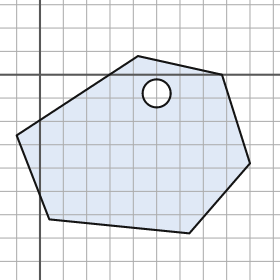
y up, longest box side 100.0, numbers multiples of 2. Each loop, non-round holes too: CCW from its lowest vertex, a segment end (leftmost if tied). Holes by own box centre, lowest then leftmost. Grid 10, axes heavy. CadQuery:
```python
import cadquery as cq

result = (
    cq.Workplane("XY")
    .moveTo(64.0, -68.0)
    .lineTo(90.0, -38.0)
    .lineTo(78.0, 0.0)
    .lineTo(42.0, 8.0)
    .lineTo(-10.0, -26.0)
    .lineTo(4.0, -62.0)
    .close()
    .moveTo(50.0, -8.0)
    .circle(6.0)
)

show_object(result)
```